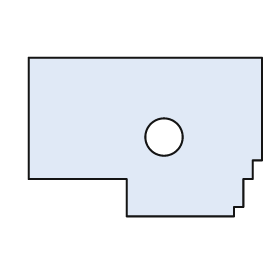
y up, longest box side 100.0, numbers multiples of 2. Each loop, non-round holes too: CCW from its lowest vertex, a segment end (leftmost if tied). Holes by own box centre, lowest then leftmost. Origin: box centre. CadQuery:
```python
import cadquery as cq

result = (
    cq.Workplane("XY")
    .moveTo(-8.0, -34.0)
    .lineTo(38.0, -34.0)
    .lineTo(38.0, -30.0)
    .lineTo(42.0, -30.0)
    .lineTo(42.0, -18.0)
    .lineTo(46.0, -18.0)
    .lineTo(46.0, -10.0)
    .lineTo(50.0, -10.0)
    .lineTo(50.0, 34.0)
    .lineTo(-50.0, 34.0)
    .lineTo(-50.0, -18.0)
    .lineTo(-8.0, -18.0)
    .close()
    .moveTo(8.0, 0.0)
    .circle(8.0)
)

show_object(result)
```